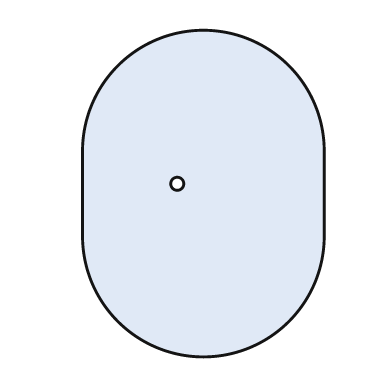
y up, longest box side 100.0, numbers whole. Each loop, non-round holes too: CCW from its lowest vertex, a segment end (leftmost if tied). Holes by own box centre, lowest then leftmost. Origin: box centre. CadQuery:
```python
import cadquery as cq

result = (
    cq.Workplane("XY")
    .moveTo(-37.0, -13.0)
    .threePointArc((0.0, -50.0), (37.0, -13.0))
    .lineTo(37.0, 13.0)
    .threePointArc((0.0, 50.0), (-37.0, 13.0))
    .close()
    .moveTo(-8.0, 3.0)
    .circle(2.0)
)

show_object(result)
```